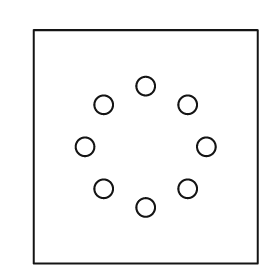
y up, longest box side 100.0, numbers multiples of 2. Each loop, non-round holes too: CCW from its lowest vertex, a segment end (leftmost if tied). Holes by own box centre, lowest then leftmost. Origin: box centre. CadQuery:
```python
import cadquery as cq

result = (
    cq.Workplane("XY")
    .moveTo(-48.0, -50.0)
    .lineTo(48.0, -50.0)
    .lineTo(48.0, 50.0)
    .lineTo(-48.0, 50.0)
    .close()
    .moveTo(0.0, -26.0)
    .circle(4.0)
    .moveTo(-18.0, -18.0)
    .circle(4.0)
    .moveTo(18.0, -18.0)
    .circle(4.0)
    .moveTo(-26.0, 0.0)
    .circle(4.0)
    .moveTo(26.0, 0.0)
    .circle(4.0)
    .moveTo(-18.0, 18.0)
    .circle(4.0)
    .moveTo(18.0, 18.0)
    .circle(4.0)
    .moveTo(0.0, 26.0)
    .circle(4.0)
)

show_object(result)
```